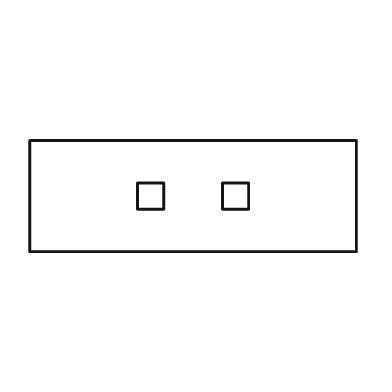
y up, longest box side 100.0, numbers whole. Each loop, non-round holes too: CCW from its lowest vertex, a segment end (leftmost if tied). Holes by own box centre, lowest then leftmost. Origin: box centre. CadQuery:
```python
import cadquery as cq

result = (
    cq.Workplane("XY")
    .moveTo(-50.0, -17.0)
    .lineTo(50.0, -17.0)
    .lineTo(50.0, 17.0)
    .lineTo(-50.0, 17.0)
    .close()
    .moveTo(-17.0, -4.0)
    .lineTo(-9.0, -4.0)
    .lineTo(-9.0, 4.0)
    .lineTo(-17.0, 4.0)
    .close()
    .moveTo(9.0, -4.0)
    .lineTo(17.0, -4.0)
    .lineTo(17.0, 4.0)
    .lineTo(9.0, 4.0)
    .close()
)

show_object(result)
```